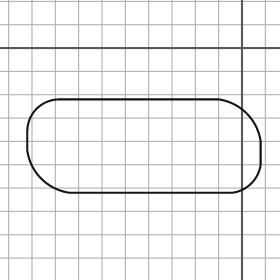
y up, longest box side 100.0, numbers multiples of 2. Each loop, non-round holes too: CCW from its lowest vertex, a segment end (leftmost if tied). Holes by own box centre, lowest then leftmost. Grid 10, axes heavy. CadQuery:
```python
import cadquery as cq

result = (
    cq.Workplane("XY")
    .moveTo(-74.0, -62.0)
    .lineTo(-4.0, -62.0)
    .threePointArc((4.0, -58.0), (8.0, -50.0))
    .lineTo(8.0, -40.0)
    .threePointArc((2.0, -28.0), (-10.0, -22.0))
    .lineTo(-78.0, -22.0)
    .threePointArc((-88.0, -26.0), (-92.0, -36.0))
    .lineTo(-92.0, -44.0)
    .threePointArc((-86.0, -56.0), (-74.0, -62.0))
    .close()
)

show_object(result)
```